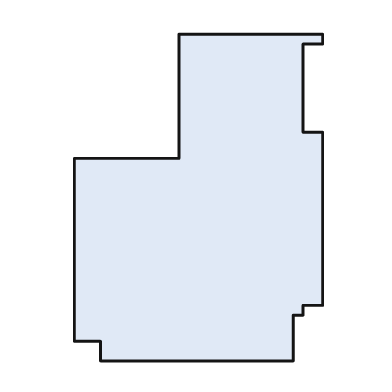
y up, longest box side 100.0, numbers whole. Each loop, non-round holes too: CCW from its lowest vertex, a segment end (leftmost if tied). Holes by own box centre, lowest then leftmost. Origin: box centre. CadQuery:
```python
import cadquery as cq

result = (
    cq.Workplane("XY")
    .moveTo(-30.0, -50.0)
    .lineTo(29.0, -50.0)
    .lineTo(29.0, -36.0)
    .lineTo(32.0, -36.0)
    .lineTo(32.0, -33.0)
    .lineTo(38.0, -33.0)
    .lineTo(38.0, 20.0)
    .lineTo(32.0, 20.0)
    .lineTo(32.0, 47.0)
    .lineTo(38.0, 47.0)
    .lineTo(38.0, 50.0)
    .lineTo(-6.0, 50.0)
    .lineTo(-6.0, 12.0)
    .lineTo(-38.0, 12.0)
    .lineTo(-38.0, -44.0)
    .lineTo(-30.0, -44.0)
    .close()
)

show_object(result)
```